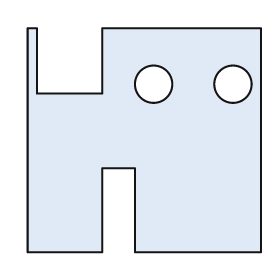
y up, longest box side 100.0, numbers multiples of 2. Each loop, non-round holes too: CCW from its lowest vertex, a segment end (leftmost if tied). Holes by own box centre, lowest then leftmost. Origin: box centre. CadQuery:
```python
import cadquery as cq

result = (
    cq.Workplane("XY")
    .moveTo(-50.0, -48.0)
    .lineTo(-18.0, -48.0)
    .lineTo(-18.0, -12.0)
    .lineTo(-4.0, -12.0)
    .lineTo(-4.0, -48.0)
    .lineTo(50.0, -48.0)
    .lineTo(50.0, 48.0)
    .lineTo(-18.0, 48.0)
    .lineTo(-18.0, 20.0)
    .lineTo(-46.0, 20.0)
    .lineTo(-46.0, 48.0)
    .lineTo(-50.0, 48.0)
    .close()
    .moveTo(4.0, 24.0)
    .circle(8.0)
    .moveTo(38.0, 24.0)
    .circle(8.0)
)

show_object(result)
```